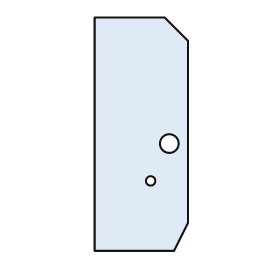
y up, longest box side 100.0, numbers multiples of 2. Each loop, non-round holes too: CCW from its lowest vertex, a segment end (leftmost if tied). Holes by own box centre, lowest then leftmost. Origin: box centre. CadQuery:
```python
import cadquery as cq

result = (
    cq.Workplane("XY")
    .moveTo(-20.0, -50.0)
    .lineTo(14.0, -50.0)
    .lineTo(20.0, -38.0)
    .lineTo(20.0, 40.0)
    .lineTo(10.0, 50.0)
    .lineTo(-20.0, 50.0)
    .close()
    .moveTo(4.0, -20.0)
    .circle(2.0)
    .moveTo(12.0, -4.0)
    .circle(4.0)
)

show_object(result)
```